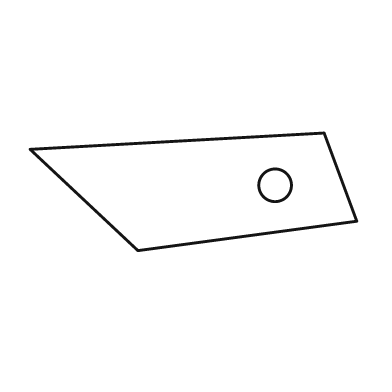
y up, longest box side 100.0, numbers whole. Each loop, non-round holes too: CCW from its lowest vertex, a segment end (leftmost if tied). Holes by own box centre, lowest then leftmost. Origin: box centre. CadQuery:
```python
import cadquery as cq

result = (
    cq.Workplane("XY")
    .moveTo(-17.0, -18.0)
    .lineTo(50.0, -9.0)
    .lineTo(40.0, 18.0)
    .lineTo(-50.0, 13.0)
    .close()
    .moveTo(25.0, 2.0)
    .circle(5.0)
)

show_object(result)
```